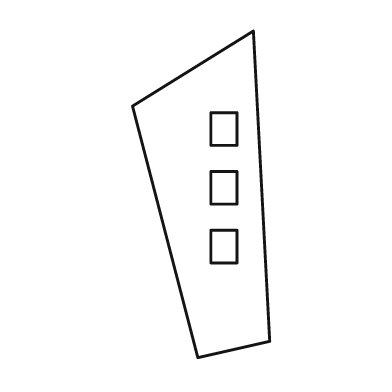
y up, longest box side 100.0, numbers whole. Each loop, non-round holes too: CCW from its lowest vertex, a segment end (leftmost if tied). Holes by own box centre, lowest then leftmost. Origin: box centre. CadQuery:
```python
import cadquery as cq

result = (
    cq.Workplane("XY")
    .moveTo(-1.0, -50.0)
    .lineTo(21.0, -45.0)
    .lineTo(16.0, 50.0)
    .lineTo(-21.0, 27.0)
    .close()
    .moveTo(3.0, -21.0)
    .lineTo(11.0, -21.0)
    .lineTo(11.0, -11.0)
    .lineTo(3.0, -11.0)
    .close()
    .moveTo(3.0, -3.0)
    .lineTo(11.0, -3.0)
    .lineTo(11.0, 7.0)
    .lineTo(3.0, 7.0)
    .close()
    .moveTo(3.0, 15.0)
    .lineTo(11.0, 15.0)
    .lineTo(11.0, 25.0)
    .lineTo(3.0, 25.0)
    .close()
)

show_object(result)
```